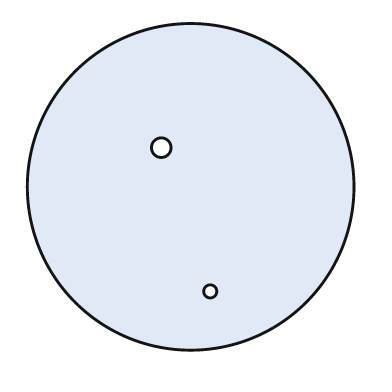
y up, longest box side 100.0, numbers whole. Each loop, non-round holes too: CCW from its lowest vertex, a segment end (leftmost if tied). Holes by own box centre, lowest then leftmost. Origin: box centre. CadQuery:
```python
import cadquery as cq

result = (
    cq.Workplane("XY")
    .moveTo(0.0, 0.0)
    .circle(50.0)
    .moveTo(6.0, -32.0)
    .circle(2.0)
    .moveTo(-9.0, 12.0)
    .circle(3.0)
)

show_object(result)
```